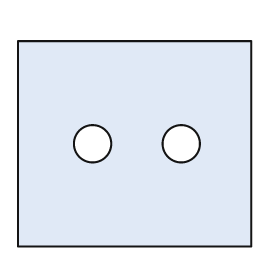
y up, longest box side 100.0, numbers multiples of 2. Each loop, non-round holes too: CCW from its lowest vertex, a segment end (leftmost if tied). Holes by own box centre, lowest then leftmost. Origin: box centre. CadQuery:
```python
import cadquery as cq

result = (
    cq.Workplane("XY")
    .moveTo(-50.0, -44.0)
    .lineTo(50.0, -44.0)
    .lineTo(50.0, 44.0)
    .lineTo(-50.0, 44.0)
    .close()
    .moveTo(-18.0, 0.0)
    .circle(8.0)
    .moveTo(20.0, 0.0)
    .circle(8.0)
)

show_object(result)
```